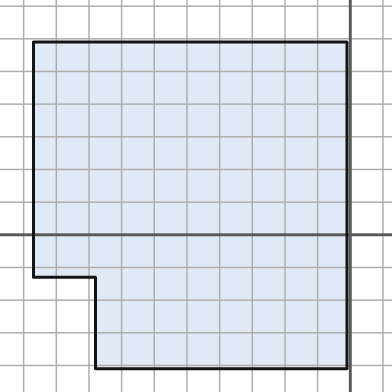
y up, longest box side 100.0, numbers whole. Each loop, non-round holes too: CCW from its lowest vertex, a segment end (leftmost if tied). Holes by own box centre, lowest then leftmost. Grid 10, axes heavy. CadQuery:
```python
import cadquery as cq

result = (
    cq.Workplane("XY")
    .moveTo(-78.0, -41.0)
    .lineTo(-1.0, -41.0)
    .lineTo(-1.0, 59.0)
    .lineTo(-97.0, 59.0)
    .lineTo(-97.0, -13.0)
    .lineTo(-78.0, -13.0)
    .close()
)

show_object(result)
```